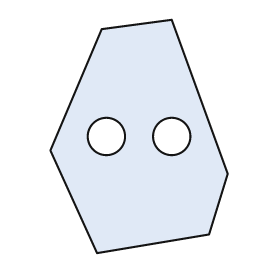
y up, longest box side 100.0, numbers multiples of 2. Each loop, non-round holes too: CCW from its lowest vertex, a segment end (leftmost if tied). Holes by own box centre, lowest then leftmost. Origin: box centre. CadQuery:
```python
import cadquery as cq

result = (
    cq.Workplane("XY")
    .moveTo(-18.0, -50.0)
    .lineTo(30.0, -42.0)
    .lineTo(38.0, -16.0)
    .lineTo(14.0, 50.0)
    .lineTo(-16.0, 46.0)
    .lineTo(-38.0, -6.0)
    .close()
    .moveTo(-14.0, 0.0)
    .circle(8.0)
    .moveTo(14.0, 0.0)
    .circle(8.0)
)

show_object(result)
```